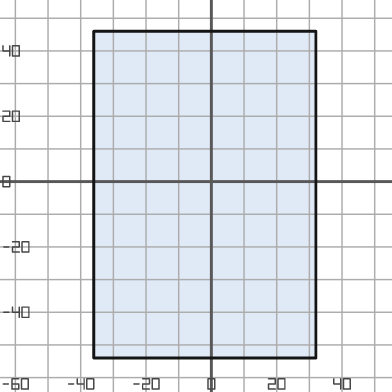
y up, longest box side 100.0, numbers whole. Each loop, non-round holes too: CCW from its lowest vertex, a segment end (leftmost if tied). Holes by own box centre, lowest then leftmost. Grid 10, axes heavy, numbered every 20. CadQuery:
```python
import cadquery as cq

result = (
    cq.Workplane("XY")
    .moveTo(-36.0, -54.0)
    .lineTo(32.0, -54.0)
    .lineTo(32.0, 46.0)
    .lineTo(-36.0, 46.0)
    .close()
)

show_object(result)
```